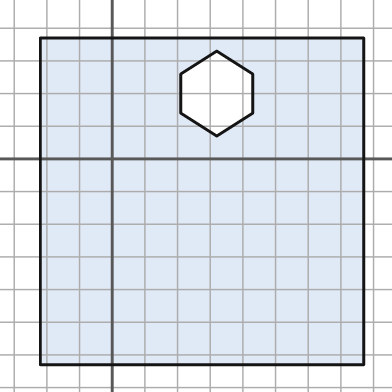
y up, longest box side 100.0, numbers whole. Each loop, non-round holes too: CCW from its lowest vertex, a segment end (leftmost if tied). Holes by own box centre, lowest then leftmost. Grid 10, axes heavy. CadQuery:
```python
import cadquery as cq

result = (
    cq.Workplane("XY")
    .moveTo(-22.0, -63.0)
    .lineTo(77.0, -63.0)
    .lineTo(77.0, 37.0)
    .lineTo(-22.0, 37.0)
    .close()
    .moveTo(32.0, 7.0)
    .lineTo(43.0, 14.0)
    .lineTo(43.0, 26.0)
    .lineTo(32.0, 33.0)
    .lineTo(21.0, 26.0)
    .lineTo(21.0, 14.0)
    .close()
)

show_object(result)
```